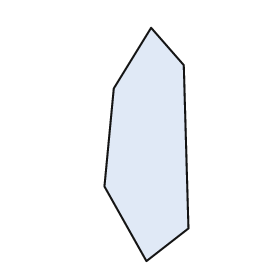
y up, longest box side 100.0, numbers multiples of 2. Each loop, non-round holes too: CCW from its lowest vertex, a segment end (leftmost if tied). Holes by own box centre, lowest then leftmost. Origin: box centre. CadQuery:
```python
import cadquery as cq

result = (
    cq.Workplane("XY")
    .moveTo(0.0, -50.0)
    .lineTo(18.0, -36.0)
    .lineTo(16.0, 34.0)
    .lineTo(2.0, 50.0)
    .lineTo(-14.0, 24.0)
    .lineTo(-18.0, -18.0)
    .close()
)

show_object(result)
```